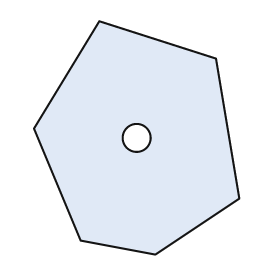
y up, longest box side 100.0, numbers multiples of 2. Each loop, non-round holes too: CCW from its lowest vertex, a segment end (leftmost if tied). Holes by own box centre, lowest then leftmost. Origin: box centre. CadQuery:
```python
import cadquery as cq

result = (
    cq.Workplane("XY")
    .moveTo(8.0, -50.0)
    .lineTo(44.0, -26.0)
    .lineTo(34.0, 34.0)
    .lineTo(-16.0, 50.0)
    .lineTo(-44.0, 4.0)
    .lineTo(-24.0, -44.0)
    .close()
    .moveTo(0.0, 0.0)
    .circle(6.0)
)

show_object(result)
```